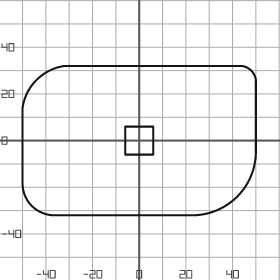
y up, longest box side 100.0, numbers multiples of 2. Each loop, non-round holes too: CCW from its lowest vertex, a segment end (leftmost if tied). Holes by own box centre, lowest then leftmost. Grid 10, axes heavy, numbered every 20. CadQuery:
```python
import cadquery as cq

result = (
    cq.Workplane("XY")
    .moveTo(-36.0, -32.0)
    .lineTo(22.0, -32.0)
    .threePointArc((42.0, -24.0), (50.0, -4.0))
    .lineTo(50.0, 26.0)
    .threePointArc((48.0, 30.0), (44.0, 32.0))
    .lineTo(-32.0, 32.0)
    .threePointArc((-44.0, 26.0), (-50.0, 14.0))
    .lineTo(-50.0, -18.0)
    .threePointArc((-46.0, -28.0), (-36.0, -32.0))
    .close()
    .moveTo(-6.0, -6.0)
    .lineTo(6.0, -6.0)
    .lineTo(6.0, 6.0)
    .lineTo(-6.0, 6.0)
    .close()
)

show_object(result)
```